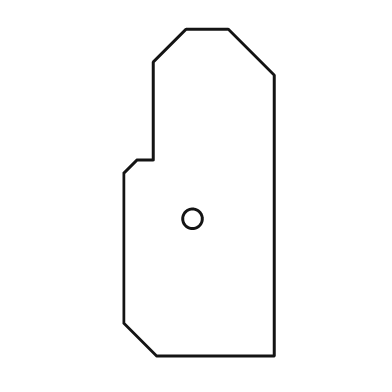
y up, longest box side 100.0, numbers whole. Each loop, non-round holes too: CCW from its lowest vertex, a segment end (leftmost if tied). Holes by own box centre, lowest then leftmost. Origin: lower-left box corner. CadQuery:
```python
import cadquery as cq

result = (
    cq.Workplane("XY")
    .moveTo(10.0, 0.0)
    .lineTo(46.0, 0.0)
    .lineTo(46.0, 86.0)
    .lineTo(32.0, 100.0)
    .lineTo(19.0, 100.0)
    .lineTo(9.0, 90.0)
    .lineTo(9.0, 60.0)
    .lineTo(4.0, 60.0)
    .lineTo(0.0, 56.0)
    .lineTo(0.0, 10.0)
    .close()
    .moveTo(21.0, 42.0)
    .circle(3.0)
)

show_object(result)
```